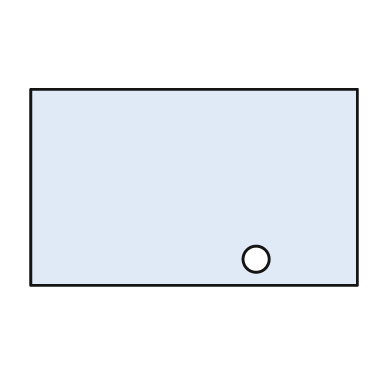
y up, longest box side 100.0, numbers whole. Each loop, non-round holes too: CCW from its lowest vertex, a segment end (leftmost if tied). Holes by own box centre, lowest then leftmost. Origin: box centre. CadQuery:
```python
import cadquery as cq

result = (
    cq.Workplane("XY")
    .moveTo(-50.0, -30.0)
    .lineTo(50.0, -30.0)
    .lineTo(50.0, 30.0)
    .lineTo(-50.0, 30.0)
    .close()
    .moveTo(19.0, -22.0)
    .circle(4.0)
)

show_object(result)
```